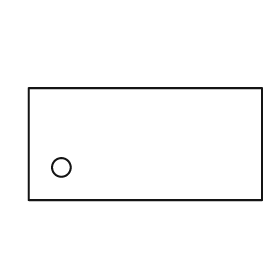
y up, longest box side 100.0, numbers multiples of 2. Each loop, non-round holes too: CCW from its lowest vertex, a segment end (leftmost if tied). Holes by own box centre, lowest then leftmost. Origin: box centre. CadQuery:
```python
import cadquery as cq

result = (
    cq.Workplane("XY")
    .moveTo(-50.0, -24.0)
    .lineTo(50.0, -24.0)
    .lineTo(50.0, 24.0)
    .lineTo(-50.0, 24.0)
    .close()
    .moveTo(-36.0, -10.0)
    .circle(4.0)
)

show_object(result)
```